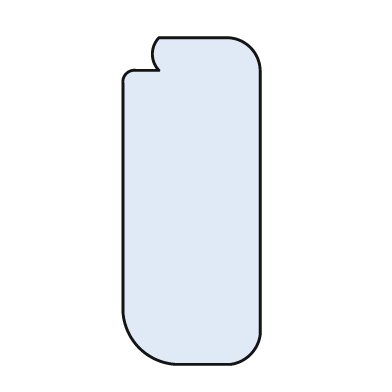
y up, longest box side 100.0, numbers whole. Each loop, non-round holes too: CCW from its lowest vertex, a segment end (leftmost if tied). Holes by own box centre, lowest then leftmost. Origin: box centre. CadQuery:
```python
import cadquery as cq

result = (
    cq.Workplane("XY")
    .moveTo(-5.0, -50.0)
    .lineTo(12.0, -50.0)
    .threePointArc((18.0, -47.0), (21.0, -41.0))
    .lineTo(21.0, 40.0)
    .threePointArc((18.0, 47.0), (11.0, 50.0))
    .lineTo(-10.0, 50.0)
    .threePointArc((-12.0, 45.0), (-10.0, 40.0))
    .lineTo(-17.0, 40.0)
    .threePointArc((-20.0, 39.0), (-21.0, 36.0))
    .lineTo(-21.0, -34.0)
    .threePointArc((-16.0, -45.0), (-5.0, -50.0))
    .close()
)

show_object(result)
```